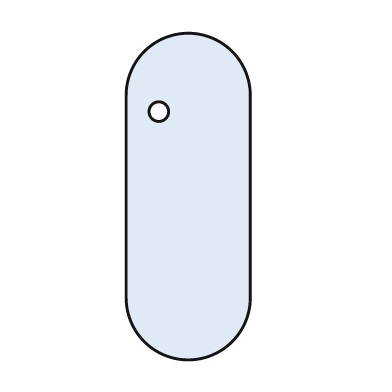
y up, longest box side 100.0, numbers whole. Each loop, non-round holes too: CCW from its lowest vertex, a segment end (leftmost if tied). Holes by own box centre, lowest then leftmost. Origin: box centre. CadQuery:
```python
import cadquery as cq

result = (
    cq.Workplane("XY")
    .moveTo(-19.0, -31.0)
    .threePointArc((0.0, -50.0), (19.0, -31.0))
    .lineTo(19.0, 31.0)
    .threePointArc((0.0, 50.0), (-19.0, 31.0))
    .close()
    .moveTo(-9.0, 26.0)
    .circle(3.0)
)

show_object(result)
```